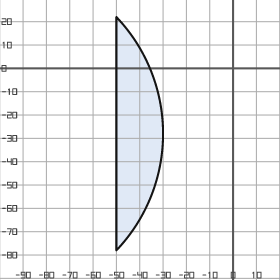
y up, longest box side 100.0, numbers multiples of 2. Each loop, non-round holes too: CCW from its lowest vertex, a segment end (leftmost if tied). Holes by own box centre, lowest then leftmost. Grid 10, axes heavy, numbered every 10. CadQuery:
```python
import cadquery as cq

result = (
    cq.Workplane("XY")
    .moveTo(-50.0, -78.0)
    .threePointArc((-30.0, -28.0), (-50.0, 22.0))
    .close()
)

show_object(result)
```